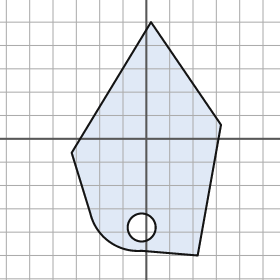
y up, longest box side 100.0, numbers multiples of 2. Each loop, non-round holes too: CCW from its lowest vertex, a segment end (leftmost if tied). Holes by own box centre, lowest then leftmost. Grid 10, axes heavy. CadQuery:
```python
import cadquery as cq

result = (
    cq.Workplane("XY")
    .moveTo(22.0, -50.0)
    .lineTo(32.0, 6.0)
    .lineTo(2.0, 50.0)
    .lineTo(-32.0, -6.0)
    .lineTo(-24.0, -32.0)
    .threePointArc((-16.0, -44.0), (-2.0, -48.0))
    .close()
    .moveTo(-2.0, -38.0)
    .circle(6.0)
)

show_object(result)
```